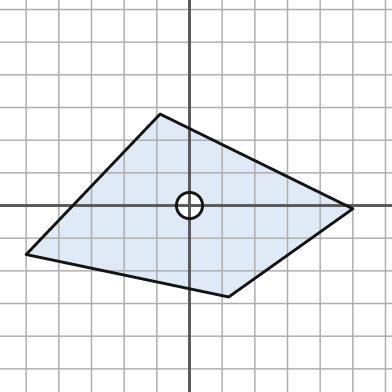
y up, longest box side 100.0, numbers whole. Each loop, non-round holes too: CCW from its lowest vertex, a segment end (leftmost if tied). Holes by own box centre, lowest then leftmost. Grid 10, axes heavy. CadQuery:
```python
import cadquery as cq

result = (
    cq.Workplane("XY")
    .moveTo(12.0, -28.0)
    .lineTo(50.0, -1.0)
    .lineTo(-9.0, 28.0)
    .lineTo(-50.0, -15.0)
    .close()
    .moveTo(0.0, 0.0)
    .circle(4.0)
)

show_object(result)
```